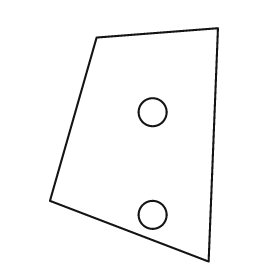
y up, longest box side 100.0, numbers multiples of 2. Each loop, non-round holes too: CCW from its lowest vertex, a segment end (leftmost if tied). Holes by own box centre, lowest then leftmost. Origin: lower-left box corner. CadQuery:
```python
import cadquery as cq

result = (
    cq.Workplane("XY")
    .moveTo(68.0, 0.0)
    .lineTo(72.0, 100.0)
    .lineTo(20.0, 96.0)
    .lineTo(0.0, 26.0)
    .close()
    .moveTo(44.0, 20.0)
    .circle(6.0)
    .moveTo(44.0, 64.0)
    .circle(6.0)
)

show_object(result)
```